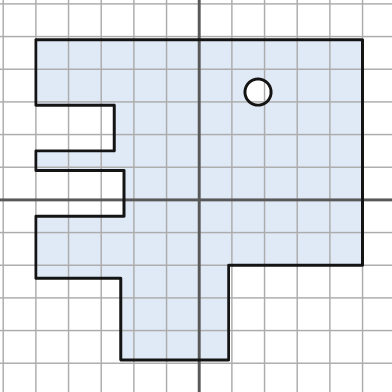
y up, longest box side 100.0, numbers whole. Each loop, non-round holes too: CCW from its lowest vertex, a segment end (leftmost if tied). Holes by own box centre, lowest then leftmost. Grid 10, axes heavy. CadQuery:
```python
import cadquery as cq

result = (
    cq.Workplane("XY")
    .moveTo(-24.0, -49.0)
    .lineTo(9.0, -49.0)
    .lineTo(9.0, -20.0)
    .lineTo(50.0, -20.0)
    .lineTo(50.0, 49.0)
    .lineTo(-50.0, 49.0)
    .lineTo(-50.0, 29.0)
    .lineTo(-26.0, 29.0)
    .lineTo(-26.0, 15.0)
    .lineTo(-50.0, 15.0)
    .lineTo(-50.0, 9.0)
    .lineTo(-23.0, 9.0)
    .lineTo(-23.0, -5.0)
    .lineTo(-50.0, -5.0)
    .lineTo(-50.0, -24.0)
    .lineTo(-24.0, -24.0)
    .close()
    .moveTo(18.0, 33.0)
    .circle(4.0)
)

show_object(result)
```